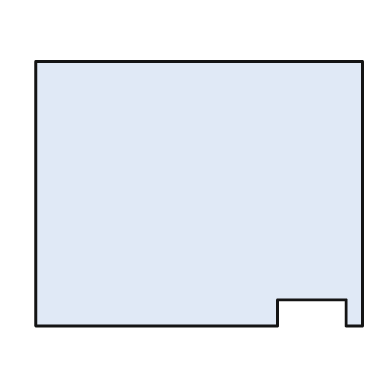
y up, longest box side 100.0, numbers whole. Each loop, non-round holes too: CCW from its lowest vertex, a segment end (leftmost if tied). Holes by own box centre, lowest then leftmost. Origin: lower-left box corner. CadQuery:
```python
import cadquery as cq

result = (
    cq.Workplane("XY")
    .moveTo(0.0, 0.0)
    .lineTo(74.0, 0.0)
    .lineTo(74.0, 8.0)
    .lineTo(95.0, 8.0)
    .lineTo(95.0, 0.0)
    .lineTo(100.0, 0.0)
    .lineTo(100.0, 81.0)
    .lineTo(0.0, 81.0)
    .close()
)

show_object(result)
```